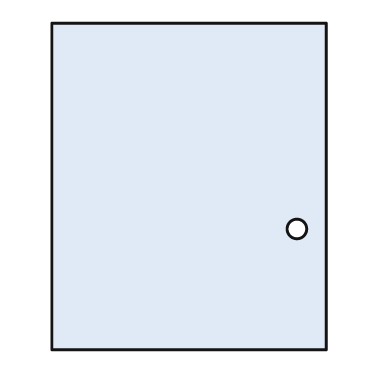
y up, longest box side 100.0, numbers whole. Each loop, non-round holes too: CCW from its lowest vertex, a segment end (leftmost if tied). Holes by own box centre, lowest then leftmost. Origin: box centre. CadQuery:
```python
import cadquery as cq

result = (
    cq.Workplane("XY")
    .moveTo(-42.0, -50.0)
    .lineTo(42.0, -50.0)
    .lineTo(42.0, 50.0)
    .lineTo(-42.0, 50.0)
    .close()
    .moveTo(33.0, -13.0)
    .circle(3.0)
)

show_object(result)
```